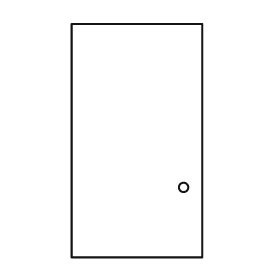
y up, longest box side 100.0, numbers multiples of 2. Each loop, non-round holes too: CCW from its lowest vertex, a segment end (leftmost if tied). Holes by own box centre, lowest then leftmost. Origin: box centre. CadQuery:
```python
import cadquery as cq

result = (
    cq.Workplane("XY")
    .moveTo(-28.0, -50.0)
    .lineTo(28.0, -50.0)
    .lineTo(28.0, 50.0)
    .lineTo(-28.0, 50.0)
    .close()
    .moveTo(20.0, -20.0)
    .circle(2.0)
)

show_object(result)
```